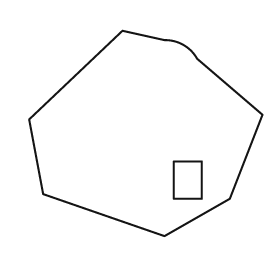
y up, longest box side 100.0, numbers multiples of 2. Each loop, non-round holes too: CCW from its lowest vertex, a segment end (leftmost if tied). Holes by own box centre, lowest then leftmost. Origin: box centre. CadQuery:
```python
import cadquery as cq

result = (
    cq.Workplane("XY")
    .moveTo(8.0, -44.0)
    .lineTo(36.0, -28.0)
    .lineTo(50.0, 8.0)
    .lineTo(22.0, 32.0)
    .threePointArc((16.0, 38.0), (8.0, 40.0))
    .lineTo(-10.0, 44.0)
    .lineTo(-50.0, 6.0)
    .lineTo(-44.0, -26.0)
    .close()
    .moveTo(12.0, -28.0)
    .lineTo(24.0, -28.0)
    .lineTo(24.0, -12.0)
    .lineTo(12.0, -12.0)
    .close()
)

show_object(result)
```